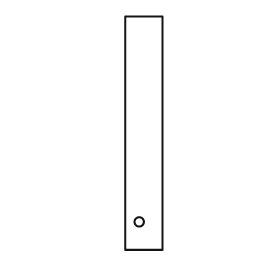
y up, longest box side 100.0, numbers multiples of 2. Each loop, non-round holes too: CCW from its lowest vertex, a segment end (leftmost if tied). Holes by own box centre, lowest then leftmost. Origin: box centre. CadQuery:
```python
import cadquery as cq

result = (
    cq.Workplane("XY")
    .moveTo(-8.0, -50.0)
    .lineTo(8.0, -50.0)
    .lineTo(8.0, 50.0)
    .lineTo(-8.0, 50.0)
    .close()
    .moveTo(-2.0, -38.0)
    .circle(2.0)
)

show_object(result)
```